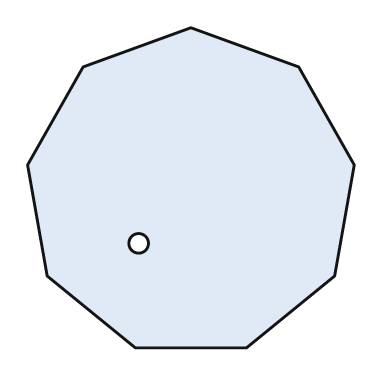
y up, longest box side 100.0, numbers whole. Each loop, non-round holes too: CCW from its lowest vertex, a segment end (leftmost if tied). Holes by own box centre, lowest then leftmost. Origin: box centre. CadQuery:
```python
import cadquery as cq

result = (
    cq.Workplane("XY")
    .moveTo(-17.0, -49.0)
    .lineTo(17.0, -49.0)
    .lineTo(44.0, -27.0)
    .lineTo(50.0, 7.0)
    .lineTo(33.0, 37.0)
    .lineTo(0.0, 49.0)
    .lineTo(-33.0, 37.0)
    .lineTo(-50.0, 7.0)
    .lineTo(-44.0, -27.0)
    .close()
    .moveTo(-16.0, -17.0)
    .circle(3.0)
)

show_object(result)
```